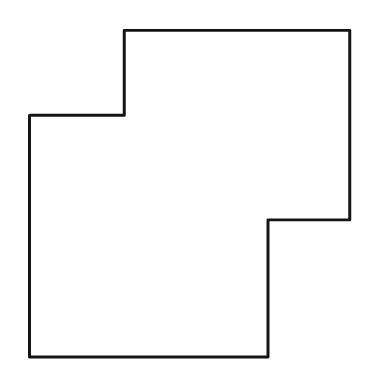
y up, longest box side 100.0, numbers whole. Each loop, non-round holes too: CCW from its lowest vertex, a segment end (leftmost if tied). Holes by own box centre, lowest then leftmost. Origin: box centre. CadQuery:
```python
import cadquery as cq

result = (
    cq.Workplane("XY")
    .moveTo(-49.0, -50.0)
    .lineTo(24.0, -50.0)
    .lineTo(24.0, -8.0)
    .lineTo(49.0, -8.0)
    .lineTo(49.0, 50.0)
    .lineTo(-20.0, 50.0)
    .lineTo(-20.0, 24.0)
    .lineTo(-49.0, 24.0)
    .close()
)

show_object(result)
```